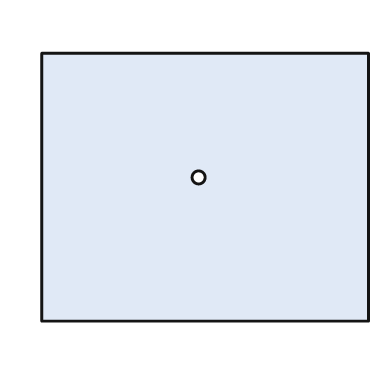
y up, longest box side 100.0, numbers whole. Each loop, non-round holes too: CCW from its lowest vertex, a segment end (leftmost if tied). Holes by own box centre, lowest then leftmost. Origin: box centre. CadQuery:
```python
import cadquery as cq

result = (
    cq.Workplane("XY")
    .moveTo(-50.0, -41.0)
    .lineTo(50.0, -41.0)
    .lineTo(50.0, 41.0)
    .lineTo(-50.0, 41.0)
    .close()
    .moveTo(-2.0, 3.0)
    .circle(2.0)
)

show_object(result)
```